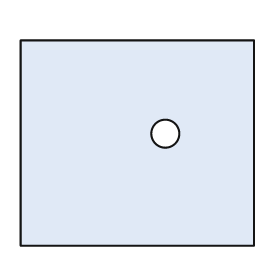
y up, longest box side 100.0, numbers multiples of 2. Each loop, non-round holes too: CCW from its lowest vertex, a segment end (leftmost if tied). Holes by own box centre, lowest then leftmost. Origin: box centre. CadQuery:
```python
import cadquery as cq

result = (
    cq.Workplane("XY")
    .moveTo(-50.0, -44.0)
    .lineTo(50.0, -44.0)
    .lineTo(50.0, 44.0)
    .lineTo(-50.0, 44.0)
    .close()
    .moveTo(12.0, 4.0)
    .circle(6.0)
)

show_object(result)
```